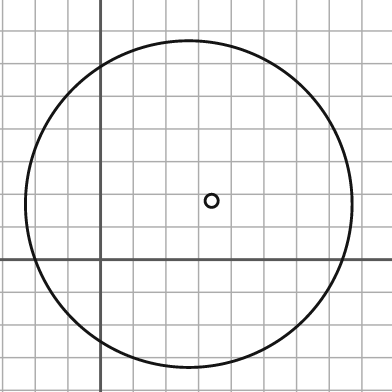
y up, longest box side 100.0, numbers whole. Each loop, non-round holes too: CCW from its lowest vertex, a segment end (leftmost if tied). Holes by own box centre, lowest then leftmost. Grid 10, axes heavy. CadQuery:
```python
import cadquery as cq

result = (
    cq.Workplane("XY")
    .moveTo(27.0, 17.0)
    .circle(50.0)
    .moveTo(34.0, 18.0)
    .circle(2.0)
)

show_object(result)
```